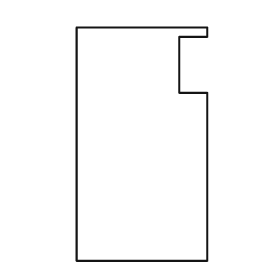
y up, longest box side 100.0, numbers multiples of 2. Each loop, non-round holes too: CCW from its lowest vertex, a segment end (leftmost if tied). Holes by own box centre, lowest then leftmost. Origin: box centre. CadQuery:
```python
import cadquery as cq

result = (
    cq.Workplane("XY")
    .moveTo(-28.0, -50.0)
    .lineTo(28.0, -50.0)
    .lineTo(28.0, 22.0)
    .lineTo(16.0, 22.0)
    .lineTo(16.0, 46.0)
    .lineTo(28.0, 46.0)
    .lineTo(28.0, 50.0)
    .lineTo(-28.0, 50.0)
    .close()
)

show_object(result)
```